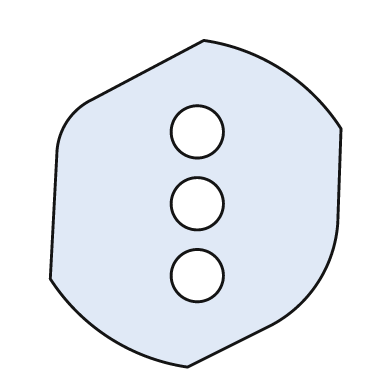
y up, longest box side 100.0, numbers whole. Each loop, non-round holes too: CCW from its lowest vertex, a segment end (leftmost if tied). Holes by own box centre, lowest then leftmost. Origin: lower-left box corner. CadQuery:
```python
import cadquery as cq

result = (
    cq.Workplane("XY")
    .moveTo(42.0, 0.0)
    .lineTo(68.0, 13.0)
    .threePointArc((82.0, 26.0), (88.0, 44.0))
    .lineTo(89.0, 73.0)
    .threePointArc((71.0, 91.0), (47.0, 100.0))
    .lineTo(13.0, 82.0)
    .threePointArc((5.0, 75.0), (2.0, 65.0))
    .lineTo(0.0, 27.0)
    .threePointArc((18.0, 9.0), (42.0, 0.0))
    .close()
    .moveTo(45.0, 28.0)
    .circle(8.0)
    .moveTo(45.0, 50.0)
    .circle(8.0)
    .moveTo(45.0, 72.0)
    .circle(8.0)
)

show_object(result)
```